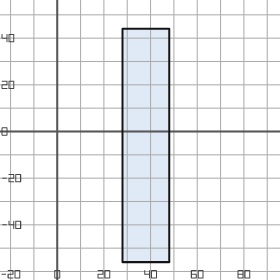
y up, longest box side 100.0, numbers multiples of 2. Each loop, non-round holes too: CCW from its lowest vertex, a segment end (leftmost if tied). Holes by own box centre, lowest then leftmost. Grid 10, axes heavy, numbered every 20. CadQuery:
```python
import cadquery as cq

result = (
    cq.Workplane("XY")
    .moveTo(28.0, -56.0)
    .lineTo(48.0, -56.0)
    .lineTo(48.0, 44.0)
    .lineTo(28.0, 44.0)
    .close()
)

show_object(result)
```